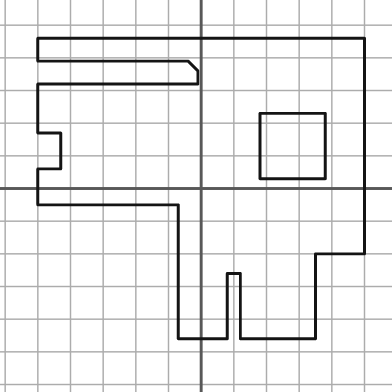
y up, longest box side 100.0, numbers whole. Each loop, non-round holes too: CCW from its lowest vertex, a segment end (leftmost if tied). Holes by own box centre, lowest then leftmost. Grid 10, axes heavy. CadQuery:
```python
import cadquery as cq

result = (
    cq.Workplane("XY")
    .moveTo(-7.0, -46.0)
    .lineTo(8.0, -46.0)
    .lineTo(8.0, -26.0)
    .lineTo(12.0, -26.0)
    .lineTo(12.0, -46.0)
    .lineTo(35.0, -46.0)
    .lineTo(35.0, -20.0)
    .lineTo(50.0, -20.0)
    .lineTo(50.0, 46.0)
    .lineTo(-50.0, 46.0)
    .lineTo(-50.0, 39.0)
    .lineTo(-4.0, 39.0)
    .lineTo(-1.0, 36.0)
    .lineTo(-1.0, 32.0)
    .lineTo(-50.0, 32.0)
    .lineTo(-50.0, 17.0)
    .lineTo(-43.0, 17.0)
    .lineTo(-43.0, 6.0)
    .lineTo(-50.0, 6.0)
    .lineTo(-50.0, -5.0)
    .lineTo(-7.0, -5.0)
    .close()
    .moveTo(18.0, 3.0)
    .lineTo(38.0, 3.0)
    .lineTo(38.0, 23.0)
    .lineTo(18.0, 23.0)
    .close()
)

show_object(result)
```